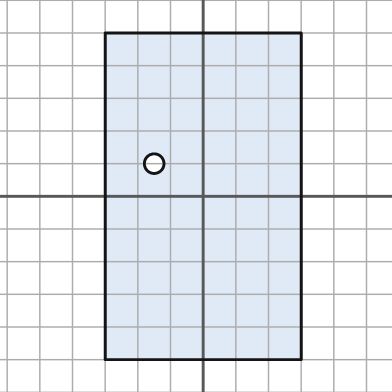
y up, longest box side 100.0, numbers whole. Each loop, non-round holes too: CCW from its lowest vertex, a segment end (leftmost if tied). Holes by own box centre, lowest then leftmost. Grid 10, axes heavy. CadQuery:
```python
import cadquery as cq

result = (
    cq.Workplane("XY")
    .moveTo(-30.0, -50.0)
    .lineTo(30.0, -50.0)
    .lineTo(30.0, 50.0)
    .lineTo(-30.0, 50.0)
    .close()
    .moveTo(-15.0, 10.0)
    .circle(3.0)
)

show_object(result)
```